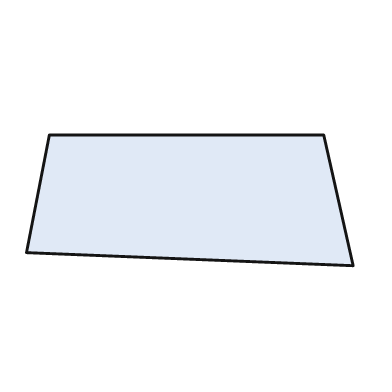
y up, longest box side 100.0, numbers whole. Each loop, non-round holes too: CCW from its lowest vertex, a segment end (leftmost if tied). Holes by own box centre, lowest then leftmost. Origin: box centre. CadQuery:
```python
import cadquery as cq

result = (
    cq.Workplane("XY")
    .moveTo(50.0, -20.0)
    .lineTo(41.0, 20.0)
    .lineTo(-43.0, 20.0)
    .lineTo(-50.0, -16.0)
    .close()
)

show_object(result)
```